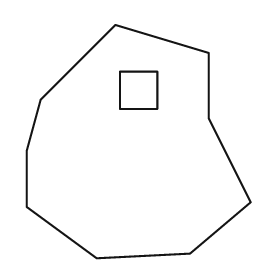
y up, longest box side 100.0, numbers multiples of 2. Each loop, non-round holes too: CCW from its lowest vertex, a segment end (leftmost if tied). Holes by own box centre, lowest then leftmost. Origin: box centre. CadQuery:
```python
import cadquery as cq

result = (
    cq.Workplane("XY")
    .moveTo(-18.0, -50.0)
    .lineTo(22.0, -48.0)
    .lineTo(48.0, -26.0)
    .lineTo(30.0, 10.0)
    .lineTo(30.0, 38.0)
    .lineTo(-10.0, 50.0)
    .lineTo(-42.0, 18.0)
    .lineTo(-48.0, -4.0)
    .lineTo(-48.0, -28.0)
    .close()
    .moveTo(-8.0, 14.0)
    .lineTo(8.0, 14.0)
    .lineTo(8.0, 30.0)
    .lineTo(-8.0, 30.0)
    .close()
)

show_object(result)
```